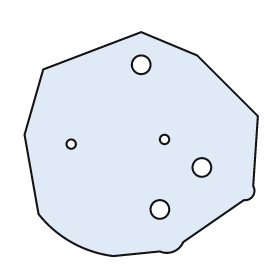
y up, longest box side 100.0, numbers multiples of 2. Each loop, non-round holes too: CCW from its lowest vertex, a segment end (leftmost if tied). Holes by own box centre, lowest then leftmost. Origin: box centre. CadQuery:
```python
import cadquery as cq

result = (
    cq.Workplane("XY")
    .moveTo(-12.0, -48.0)
    .lineTo(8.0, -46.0)
    .threePointArc((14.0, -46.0), (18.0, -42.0))
    .lineTo(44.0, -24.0)
    .threePointArc((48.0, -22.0), (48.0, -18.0))
    .lineTo(50.0, 12.0)
    .lineTo(24.0, 38.0)
    .lineTo(0.0, 48.0)
    .lineTo(-42.0, 32.0)
    .lineTo(-50.0, 4.0)
    .lineTo(-44.0, -30.0)
    .threePointArc((-30.0, -42.0), (-12.0, -48.0))
    .close()
    .moveTo(8.0, -28.0)
    .circle(4.0)
    .moveTo(26.0, -10.0)
    .circle(4.0)
    .moveTo(-30.0, 0.0)
    .circle(2.0)
    .moveTo(10.0, 2.0)
    .circle(2.0)
    .moveTo(0.0, 34.0)
    .circle(4.0)
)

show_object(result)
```